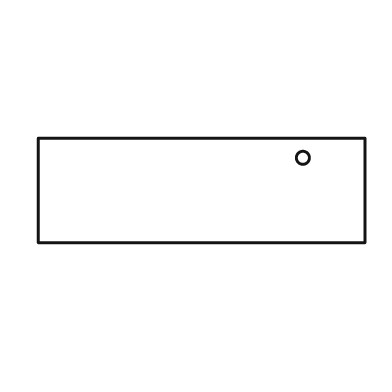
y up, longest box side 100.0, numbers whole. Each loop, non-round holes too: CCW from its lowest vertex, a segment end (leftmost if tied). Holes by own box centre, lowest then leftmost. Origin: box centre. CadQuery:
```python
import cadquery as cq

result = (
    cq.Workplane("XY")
    .moveTo(-50.0, -16.0)
    .lineTo(50.0, -16.0)
    .lineTo(50.0, 16.0)
    .lineTo(-50.0, 16.0)
    .close()
    .moveTo(31.0, 10.0)
    .circle(2.0)
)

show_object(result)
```